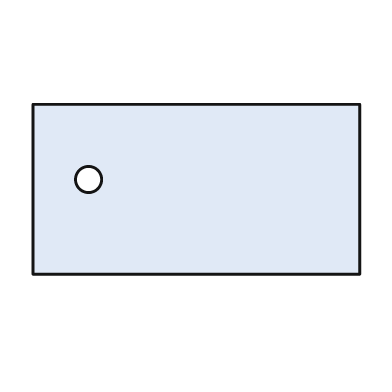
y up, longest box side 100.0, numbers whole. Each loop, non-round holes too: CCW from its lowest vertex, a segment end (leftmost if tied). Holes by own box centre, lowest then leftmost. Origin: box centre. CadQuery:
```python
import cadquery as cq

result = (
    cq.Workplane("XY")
    .moveTo(-50.0, -26.0)
    .lineTo(50.0, -26.0)
    .lineTo(50.0, 26.0)
    .lineTo(-50.0, 26.0)
    .close()
    .moveTo(-33.0, 3.0)
    .circle(4.0)
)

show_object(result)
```